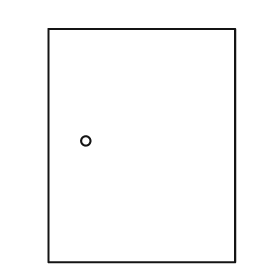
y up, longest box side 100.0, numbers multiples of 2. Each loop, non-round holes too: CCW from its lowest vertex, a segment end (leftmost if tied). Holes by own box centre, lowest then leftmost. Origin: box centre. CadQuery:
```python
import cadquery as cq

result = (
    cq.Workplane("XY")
    .moveTo(-40.0, -50.0)
    .lineTo(40.0, -50.0)
    .lineTo(40.0, 50.0)
    .lineTo(-40.0, 50.0)
    .close()
    .moveTo(-24.0, 2.0)
    .circle(2.0)
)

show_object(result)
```